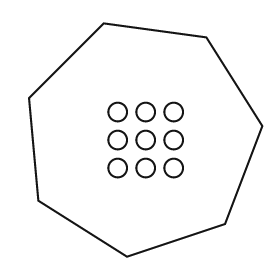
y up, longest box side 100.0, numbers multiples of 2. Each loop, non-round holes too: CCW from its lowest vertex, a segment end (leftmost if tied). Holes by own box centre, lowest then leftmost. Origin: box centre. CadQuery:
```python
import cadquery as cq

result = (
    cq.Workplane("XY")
    .moveTo(-8.0, -50.0)
    .lineTo(34.0, -36.0)
    .lineTo(50.0, 6.0)
    .lineTo(26.0, 44.0)
    .lineTo(-18.0, 50.0)
    .lineTo(-50.0, 18.0)
    .lineTo(-46.0, -26.0)
    .close()
    .moveTo(-12.0, -12.0)
    .circle(4.0)
    .moveTo(0.0, -12.0)
    .circle(4.0)
    .moveTo(12.0, -12.0)
    .circle(4.0)
    .moveTo(-12.0, 0.0)
    .circle(4.0)
    .moveTo(0.0, 0.0)
    .circle(4.0)
    .moveTo(12.0, 0.0)
    .circle(4.0)
    .moveTo(-12.0, 12.0)
    .circle(4.0)
    .moveTo(0.0, 12.0)
    .circle(4.0)
    .moveTo(12.0, 12.0)
    .circle(4.0)
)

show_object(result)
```